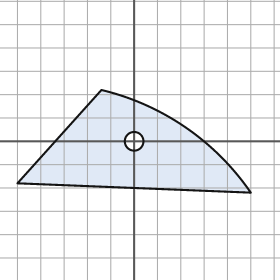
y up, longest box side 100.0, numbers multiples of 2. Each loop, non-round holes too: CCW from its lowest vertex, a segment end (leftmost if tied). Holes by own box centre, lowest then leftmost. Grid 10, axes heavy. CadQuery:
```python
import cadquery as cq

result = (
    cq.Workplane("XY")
    .moveTo(50.0, -22.0)
    .threePointArc((22.0, 6.0), (-14.0, 22.0))
    .lineTo(-50.0, -18.0)
    .close()
    .moveTo(0.0, 0.0)
    .circle(4.0)
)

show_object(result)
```